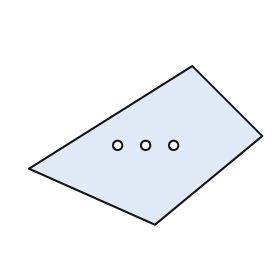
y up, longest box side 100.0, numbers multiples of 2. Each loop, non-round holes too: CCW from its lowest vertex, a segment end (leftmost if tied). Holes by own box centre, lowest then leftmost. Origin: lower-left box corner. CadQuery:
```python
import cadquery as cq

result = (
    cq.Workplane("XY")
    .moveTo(54.0, 0.0)
    .lineTo(100.0, 38.0)
    .lineTo(70.0, 68.0)
    .lineTo(0.0, 24.0)
    .close()
    .moveTo(38.0, 34.0)
    .circle(2.0)
    .moveTo(50.0, 34.0)
    .circle(2.0)
    .moveTo(62.0, 34.0)
    .circle(2.0)
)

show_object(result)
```